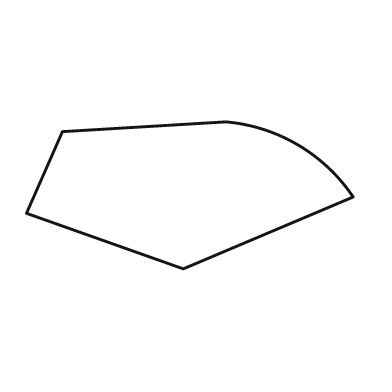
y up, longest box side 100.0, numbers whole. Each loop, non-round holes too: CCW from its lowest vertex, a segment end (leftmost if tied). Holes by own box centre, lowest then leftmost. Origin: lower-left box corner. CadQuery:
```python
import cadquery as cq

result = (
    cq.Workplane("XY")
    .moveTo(48.0, 0.0)
    .lineTo(100.0, 22.0)
    .threePointArc((83.0, 38.0), (61.0, 45.0))
    .lineTo(11.0, 42.0)
    .lineTo(0.0, 17.0)
    .close()
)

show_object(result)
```